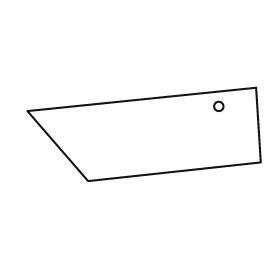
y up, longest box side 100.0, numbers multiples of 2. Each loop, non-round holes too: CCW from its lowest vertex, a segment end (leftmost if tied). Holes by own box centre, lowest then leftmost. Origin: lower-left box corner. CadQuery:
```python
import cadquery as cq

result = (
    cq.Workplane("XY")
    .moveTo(26.0, 0.0)
    .lineTo(100.0, 8.0)
    .lineTo(98.0, 40.0)
    .lineTo(0.0, 30.0)
    .close()
    .moveTo(82.0, 32.0)
    .circle(2.0)
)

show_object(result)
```